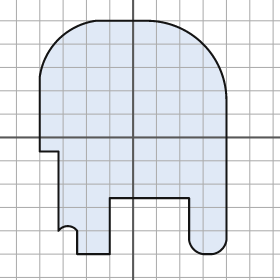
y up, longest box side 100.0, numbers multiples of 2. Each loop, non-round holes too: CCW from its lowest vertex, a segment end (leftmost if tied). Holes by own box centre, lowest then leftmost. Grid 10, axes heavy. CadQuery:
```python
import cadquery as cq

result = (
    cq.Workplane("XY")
    .moveTo(-24.0, -50.0)
    .lineTo(-10.0, -50.0)
    .lineTo(-10.0, -26.0)
    .lineTo(24.0, -26.0)
    .lineTo(24.0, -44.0)
    .threePointArc((26.0, -48.0), (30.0, -50.0))
    .lineTo(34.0, -50.0)
    .threePointArc((38.0, -48.0), (40.0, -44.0))
    .lineTo(40.0, 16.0)
    .threePointArc((30.0, 40.0), (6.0, 50.0))
    .lineTo(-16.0, 50.0)
    .threePointArc((-32.0, 42.0), (-40.0, 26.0))
    .lineTo(-40.0, -6.0)
    .lineTo(-32.0, -6.0)
    .lineTo(-32.0, -40.0)
    .threePointArc((-28.0, -38.0), (-24.0, -40.0))
    .close()
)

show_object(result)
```